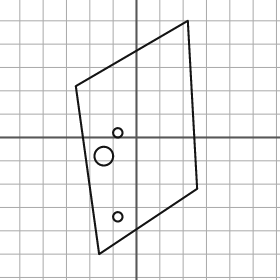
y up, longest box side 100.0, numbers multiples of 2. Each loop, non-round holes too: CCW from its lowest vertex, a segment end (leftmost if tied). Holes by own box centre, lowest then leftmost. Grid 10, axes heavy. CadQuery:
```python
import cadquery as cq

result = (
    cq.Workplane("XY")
    .moveTo(-16.0, -50.0)
    .lineTo(26.0, -22.0)
    .lineTo(22.0, 50.0)
    .lineTo(-26.0, 22.0)
    .close()
    .moveTo(-8.0, -34.0)
    .circle(2.0)
    .moveTo(-14.0, -8.0)
    .circle(4.0)
    .moveTo(-8.0, 2.0)
    .circle(2.0)
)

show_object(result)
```